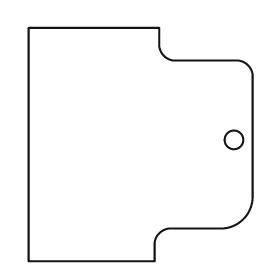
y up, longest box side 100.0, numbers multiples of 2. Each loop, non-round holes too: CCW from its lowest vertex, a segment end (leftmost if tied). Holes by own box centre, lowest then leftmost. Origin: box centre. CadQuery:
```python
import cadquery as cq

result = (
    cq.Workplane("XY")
    .moveTo(-48.0, -50.0)
    .lineTo(6.0, -50.0)
    .lineTo(6.0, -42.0)
    .threePointArc((8.0, -38.0), (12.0, -36.0))
    .lineTo(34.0, -36.0)
    .threePointArc((44.0, -32.0), (48.0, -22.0))
    .lineTo(48.0, 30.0)
    .threePointArc((46.0, 34.0), (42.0, 36.0))
    .lineTo(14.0, 36.0)
    .threePointArc((10.0, 38.0), (8.0, 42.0))
    .lineTo(8.0, 50.0)
    .lineTo(-48.0, 50.0)
    .close()
    .moveTo(40.0, 2.0)
    .circle(4.0)
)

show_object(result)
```